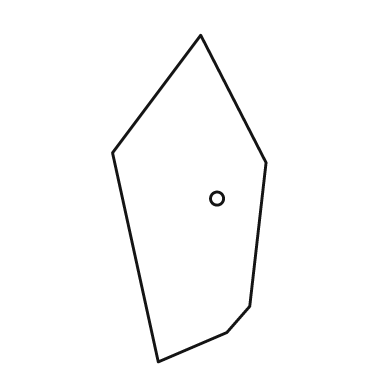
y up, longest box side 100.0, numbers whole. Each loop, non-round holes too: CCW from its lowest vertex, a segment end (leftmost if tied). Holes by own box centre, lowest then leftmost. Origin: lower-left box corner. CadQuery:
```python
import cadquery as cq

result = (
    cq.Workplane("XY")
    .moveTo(14.0, 0.0)
    .lineTo(35.0, 9.0)
    .lineTo(42.0, 17.0)
    .lineTo(47.0, 61.0)
    .lineTo(27.0, 100.0)
    .lineTo(0.0, 64.0)
    .close()
    .moveTo(32.0, 50.0)
    .circle(2.0)
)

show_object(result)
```